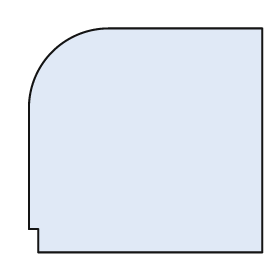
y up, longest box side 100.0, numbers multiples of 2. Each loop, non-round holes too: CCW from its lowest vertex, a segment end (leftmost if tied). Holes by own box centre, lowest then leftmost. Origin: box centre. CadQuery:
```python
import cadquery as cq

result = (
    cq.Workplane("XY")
    .moveTo(-46.0, -48.0)
    .lineTo(50.0, -48.0)
    .lineTo(50.0, 48.0)
    .lineTo(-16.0, 48.0)
    .threePointArc((-40.0, 38.0), (-50.0, 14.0))
    .lineTo(-50.0, -38.0)
    .lineTo(-46.0, -38.0)
    .close()
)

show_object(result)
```